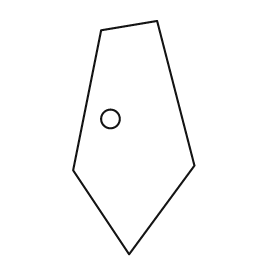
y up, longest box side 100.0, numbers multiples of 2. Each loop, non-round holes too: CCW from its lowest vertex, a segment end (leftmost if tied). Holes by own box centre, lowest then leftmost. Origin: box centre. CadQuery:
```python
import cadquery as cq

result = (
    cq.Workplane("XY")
    .moveTo(-2.0, -50.0)
    .lineTo(26.0, -12.0)
    .lineTo(10.0, 50.0)
    .lineTo(-14.0, 46.0)
    .lineTo(-26.0, -14.0)
    .close()
    .moveTo(-10.0, 8.0)
    .circle(4.0)
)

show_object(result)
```